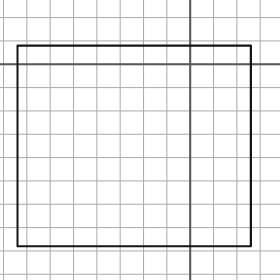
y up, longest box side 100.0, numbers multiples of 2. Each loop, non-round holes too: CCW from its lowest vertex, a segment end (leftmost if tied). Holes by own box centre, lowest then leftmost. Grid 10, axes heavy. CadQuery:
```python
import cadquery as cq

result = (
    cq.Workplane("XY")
    .moveTo(-74.0, -78.0)
    .lineTo(26.0, -78.0)
    .lineTo(26.0, 8.0)
    .lineTo(-74.0, 8.0)
    .close()
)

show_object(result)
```